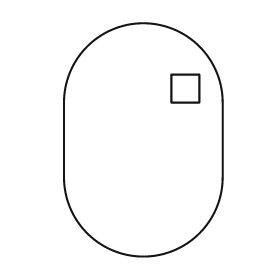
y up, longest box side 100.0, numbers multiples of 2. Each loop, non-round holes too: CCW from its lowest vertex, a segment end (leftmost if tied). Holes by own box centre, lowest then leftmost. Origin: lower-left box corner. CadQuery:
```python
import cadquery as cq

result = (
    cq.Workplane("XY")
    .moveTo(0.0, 34.0)
    .threePointArc((34.0, 0.0), (68.0, 34.0))
    .lineTo(68.0, 66.0)
    .threePointArc((34.0, 100.0), (0.0, 66.0))
    .close()
    .moveTo(46.0, 66.0)
    .lineTo(58.0, 66.0)
    .lineTo(58.0, 78.0)
    .lineTo(46.0, 78.0)
    .close()
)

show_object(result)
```